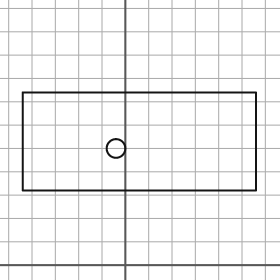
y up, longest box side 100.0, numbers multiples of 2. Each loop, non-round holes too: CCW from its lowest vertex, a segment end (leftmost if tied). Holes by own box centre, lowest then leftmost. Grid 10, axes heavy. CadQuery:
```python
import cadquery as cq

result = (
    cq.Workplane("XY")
    .moveTo(-44.0, 32.0)
    .lineTo(56.0, 32.0)
    .lineTo(56.0, 74.0)
    .lineTo(-44.0, 74.0)
    .close()
    .moveTo(-4.0, 50.0)
    .circle(4.0)
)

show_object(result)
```